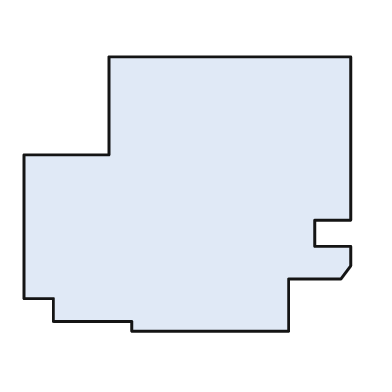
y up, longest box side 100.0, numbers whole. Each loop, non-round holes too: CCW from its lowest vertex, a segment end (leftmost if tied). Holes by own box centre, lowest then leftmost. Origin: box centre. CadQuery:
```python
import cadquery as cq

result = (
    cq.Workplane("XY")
    .moveTo(-17.0, -42.0)
    .lineTo(31.0, -42.0)
    .lineTo(31.0, -26.0)
    .lineTo(47.0, -26.0)
    .lineTo(50.0, -22.0)
    .lineTo(50.0, -16.0)
    .lineTo(39.0, -16.0)
    .lineTo(39.0, -8.0)
    .lineTo(50.0, -8.0)
    .lineTo(50.0, 42.0)
    .lineTo(-24.0, 42.0)
    .lineTo(-24.0, 12.0)
    .lineTo(-50.0, 12.0)
    .lineTo(-50.0, -32.0)
    .lineTo(-41.0, -32.0)
    .lineTo(-41.0, -39.0)
    .lineTo(-17.0, -39.0)
    .close()
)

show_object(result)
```